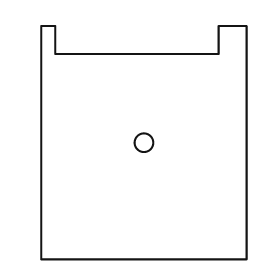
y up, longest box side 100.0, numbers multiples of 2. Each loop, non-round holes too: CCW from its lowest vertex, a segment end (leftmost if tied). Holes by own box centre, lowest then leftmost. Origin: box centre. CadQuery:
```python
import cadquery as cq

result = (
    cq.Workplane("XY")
    .moveTo(-44.0, -50.0)
    .lineTo(44.0, -50.0)
    .lineTo(44.0, 50.0)
    .lineTo(32.0, 50.0)
    .lineTo(32.0, 38.0)
    .lineTo(-38.0, 38.0)
    .lineTo(-38.0, 50.0)
    .lineTo(-44.0, 50.0)
    .close()
    .moveTo(0.0, 0.0)
    .circle(4.0)
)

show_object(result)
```